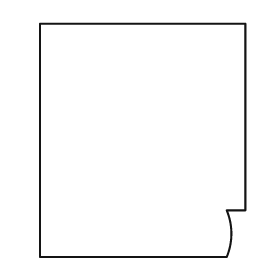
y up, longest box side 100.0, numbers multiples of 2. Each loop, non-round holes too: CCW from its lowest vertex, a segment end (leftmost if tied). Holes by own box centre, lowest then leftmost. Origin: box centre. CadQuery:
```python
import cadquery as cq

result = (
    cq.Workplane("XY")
    .moveTo(-44.0, -50.0)
    .lineTo(36.0, -50.0)
    .threePointArc((38.0, -40.0), (36.0, -30.0))
    .lineTo(44.0, -30.0)
    .lineTo(44.0, 50.0)
    .lineTo(-44.0, 50.0)
    .close()
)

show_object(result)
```